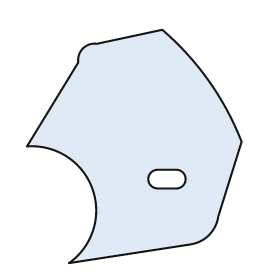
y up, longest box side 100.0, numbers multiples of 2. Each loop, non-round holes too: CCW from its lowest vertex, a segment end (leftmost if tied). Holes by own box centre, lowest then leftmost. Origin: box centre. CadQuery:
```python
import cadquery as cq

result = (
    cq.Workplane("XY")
    .moveTo(-28.0, -50.0)
    .lineTo(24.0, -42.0)
    .threePointArc((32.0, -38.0), (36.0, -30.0))
    .lineTo(46.0, 2.0)
    .threePointArc((32.0, 28.0), (12.0, 50.0))
    .lineTo(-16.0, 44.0)
    .threePointArc((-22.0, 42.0), (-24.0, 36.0))
    .lineTo(-46.0, 0.0)
    .threePointArc((-18.0, -18.0), (-28.0, -50.0))
    .close()
    .moveTo(10.0, -18.0)
    .lineTo(18.0, -18.0)
    .threePointArc((22.0, -14.0), (18.0, -10.0))
    .lineTo(10.0, -10.0)
    .threePointArc((6.0, -14.0), (10.0, -18.0))
    .close()
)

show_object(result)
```